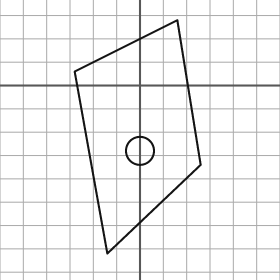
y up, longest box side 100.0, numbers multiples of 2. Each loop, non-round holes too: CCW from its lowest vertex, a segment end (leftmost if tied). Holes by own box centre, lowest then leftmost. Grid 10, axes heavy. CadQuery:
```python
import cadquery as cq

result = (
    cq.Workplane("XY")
    .moveTo(-14.0, -72.0)
    .lineTo(26.0, -34.0)
    .lineTo(16.0, 28.0)
    .lineTo(-28.0, 6.0)
    .close()
    .moveTo(0.0, -28.0)
    .circle(6.0)
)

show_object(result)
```